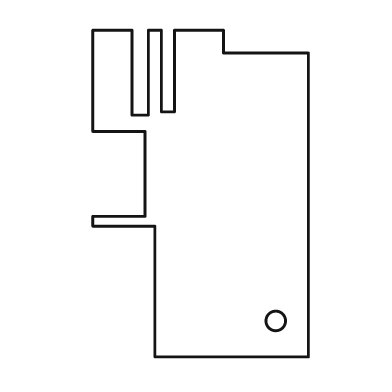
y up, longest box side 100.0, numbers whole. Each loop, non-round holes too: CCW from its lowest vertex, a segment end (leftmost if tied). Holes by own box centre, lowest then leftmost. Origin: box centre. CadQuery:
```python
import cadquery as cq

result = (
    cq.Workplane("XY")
    .moveTo(-14.0, -50.0)
    .lineTo(33.0, -50.0)
    .lineTo(33.0, 43.0)
    .lineTo(7.0, 43.0)
    .lineTo(7.0, 50.0)
    .lineTo(-8.0, 50.0)
    .lineTo(-8.0, 25.0)
    .lineTo(-12.0, 25.0)
    .lineTo(-12.0, 50.0)
    .lineTo(-16.0, 50.0)
    .lineTo(-16.0, 24.0)
    .lineTo(-21.0, 24.0)
    .lineTo(-21.0, 50.0)
    .lineTo(-33.0, 50.0)
    .lineTo(-33.0, 19.0)
    .lineTo(-17.0, 19.0)
    .lineTo(-17.0, -7.0)
    .lineTo(-33.0, -7.0)
    .lineTo(-33.0, -10.0)
    .lineTo(-14.0, -10.0)
    .close()
    .moveTo(23.0, -39.0)
    .circle(3.0)
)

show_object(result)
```